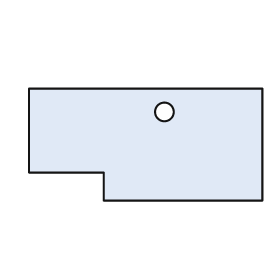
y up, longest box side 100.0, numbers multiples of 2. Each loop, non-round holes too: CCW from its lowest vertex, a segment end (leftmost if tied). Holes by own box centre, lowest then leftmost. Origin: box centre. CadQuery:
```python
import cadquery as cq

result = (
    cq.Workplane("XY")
    .moveTo(-18.0, -24.0)
    .lineTo(50.0, -24.0)
    .lineTo(50.0, 24.0)
    .lineTo(-50.0, 24.0)
    .lineTo(-50.0, -12.0)
    .lineTo(-18.0, -12.0)
    .close()
    .moveTo(8.0, 14.0)
    .circle(4.0)
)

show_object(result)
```